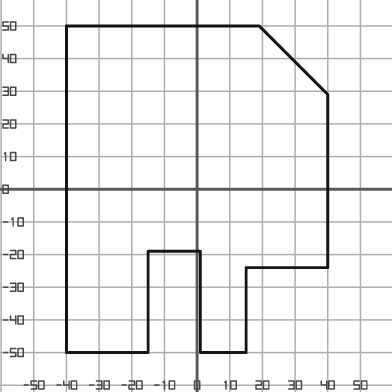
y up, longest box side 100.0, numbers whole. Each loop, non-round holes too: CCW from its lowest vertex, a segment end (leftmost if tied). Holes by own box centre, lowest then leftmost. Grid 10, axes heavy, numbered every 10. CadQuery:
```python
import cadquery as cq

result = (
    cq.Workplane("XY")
    .moveTo(-40.0, -50.0)
    .lineTo(-15.0, -50.0)
    .lineTo(-15.0, -19.0)
    .lineTo(1.0, -19.0)
    .lineTo(1.0, -50.0)
    .lineTo(15.0, -50.0)
    .lineTo(15.0, -24.0)
    .lineTo(40.0, -24.0)
    .lineTo(40.0, 29.0)
    .lineTo(19.0, 50.0)
    .lineTo(-40.0, 50.0)
    .close()
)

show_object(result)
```